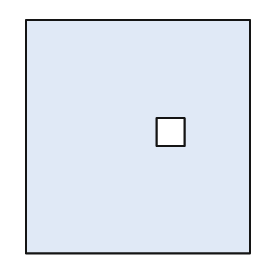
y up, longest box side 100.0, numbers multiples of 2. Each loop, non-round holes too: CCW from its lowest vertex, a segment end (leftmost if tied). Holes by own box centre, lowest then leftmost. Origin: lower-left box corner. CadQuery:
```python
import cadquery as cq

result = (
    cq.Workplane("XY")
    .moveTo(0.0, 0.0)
    .lineTo(96.0, 0.0)
    .lineTo(96.0, 100.0)
    .lineTo(0.0, 100.0)
    .close()
    .moveTo(56.0, 46.0)
    .lineTo(68.0, 46.0)
    .lineTo(68.0, 58.0)
    .lineTo(56.0, 58.0)
    .close()
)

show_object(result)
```